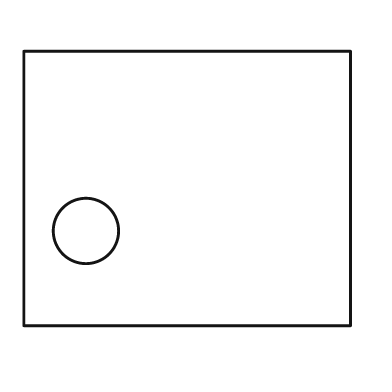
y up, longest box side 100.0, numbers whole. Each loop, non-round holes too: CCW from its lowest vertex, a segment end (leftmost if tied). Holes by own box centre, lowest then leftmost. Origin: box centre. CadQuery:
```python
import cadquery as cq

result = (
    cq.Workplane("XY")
    .moveTo(-50.0, -42.0)
    .lineTo(50.0, -42.0)
    .lineTo(50.0, 42.0)
    .lineTo(-50.0, 42.0)
    .close()
    .moveTo(-31.0, -13.0)
    .circle(10.0)
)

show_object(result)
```